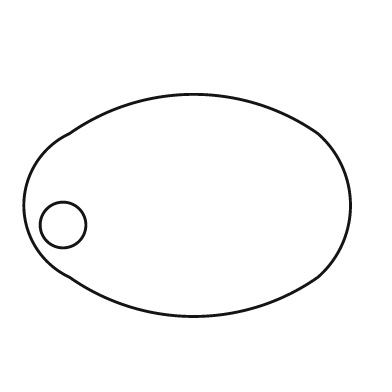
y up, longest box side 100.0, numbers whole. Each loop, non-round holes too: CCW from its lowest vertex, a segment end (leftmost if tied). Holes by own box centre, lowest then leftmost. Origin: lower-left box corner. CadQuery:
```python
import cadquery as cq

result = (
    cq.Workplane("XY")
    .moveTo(14.0, 12.0)
    .threePointArc((52.0, 0.0), (90.0, 12.0))
    .threePointArc((100.0, 34.0), (90.0, 56.0))
    .threePointArc((52.0, 68.0), (14.0, 56.0))
    .threePointArc((0.0, 34.0), (14.0, 12.0))
    .close()
    .moveTo(12.0, 28.0)
    .circle(7.0)
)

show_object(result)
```